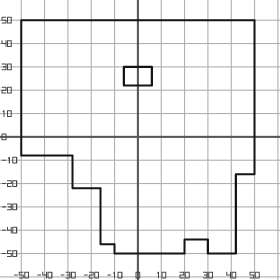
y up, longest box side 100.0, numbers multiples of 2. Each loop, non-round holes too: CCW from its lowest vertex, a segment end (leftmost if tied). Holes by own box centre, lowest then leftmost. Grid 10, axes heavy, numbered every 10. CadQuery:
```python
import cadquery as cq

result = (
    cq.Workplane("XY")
    .moveTo(-10.0, -50.0)
    .lineTo(20.0, -50.0)
    .lineTo(20.0, -44.0)
    .lineTo(30.0, -44.0)
    .lineTo(30.0, -50.0)
    .lineTo(42.0, -50.0)
    .lineTo(42.0, -16.0)
    .lineTo(50.0, -16.0)
    .lineTo(50.0, 50.0)
    .lineTo(-50.0, 50.0)
    .lineTo(-50.0, -8.0)
    .lineTo(-28.0, -8.0)
    .lineTo(-28.0, -22.0)
    .lineTo(-16.0, -22.0)
    .lineTo(-16.0, -46.0)
    .lineTo(-10.0, -46.0)
    .close()
    .moveTo(-6.0, 22.0)
    .lineTo(6.0, 22.0)
    .lineTo(6.0, 30.0)
    .lineTo(-6.0, 30.0)
    .close()
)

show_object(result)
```